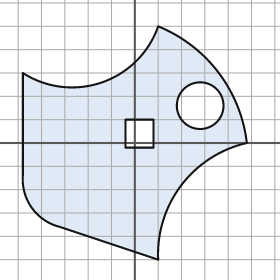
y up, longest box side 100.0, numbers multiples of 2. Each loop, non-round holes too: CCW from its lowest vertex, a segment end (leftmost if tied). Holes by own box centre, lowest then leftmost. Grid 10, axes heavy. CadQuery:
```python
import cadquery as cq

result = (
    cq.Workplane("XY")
    .moveTo(10.0, -50.0)
    .threePointArc((20.0, -18.0), (48.0, 0.0))
    .threePointArc((36.0, 30.0), (10.0, 50.0))
    .threePointArc((-14.0, 26.0), (-48.0, 30.0))
    .lineTo(-48.0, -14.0)
    .threePointArc((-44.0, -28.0), (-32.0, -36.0))
    .close()
    .moveTo(-4.0, -2.0)
    .lineTo(8.0, -2.0)
    .lineTo(8.0, 10.0)
    .lineTo(-4.0, 10.0)
    .close()
    .moveTo(28.0, 16.0)
    .circle(10.0)
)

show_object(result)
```